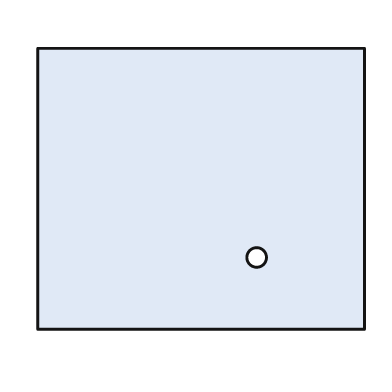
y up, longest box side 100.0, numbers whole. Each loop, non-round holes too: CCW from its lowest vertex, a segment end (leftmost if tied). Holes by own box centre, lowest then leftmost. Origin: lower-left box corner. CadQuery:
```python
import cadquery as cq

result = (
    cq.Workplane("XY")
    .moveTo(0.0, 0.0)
    .lineTo(100.0, 0.0)
    .lineTo(100.0, 86.0)
    .lineTo(0.0, 86.0)
    .close()
    .moveTo(67.0, 22.0)
    .circle(3.0)
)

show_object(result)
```